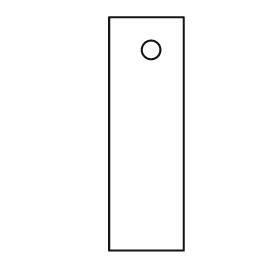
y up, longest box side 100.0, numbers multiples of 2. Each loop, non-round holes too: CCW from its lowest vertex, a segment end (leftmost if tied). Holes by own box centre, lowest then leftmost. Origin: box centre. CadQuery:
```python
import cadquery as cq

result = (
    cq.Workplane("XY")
    .moveTo(-16.0, -50.0)
    .lineTo(16.0, -50.0)
    .lineTo(16.0, 50.0)
    .lineTo(-16.0, 50.0)
    .close()
    .moveTo(2.0, 36.0)
    .circle(4.0)
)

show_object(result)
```